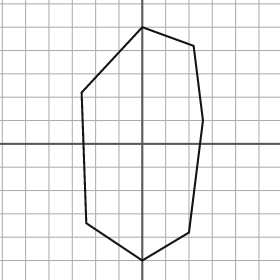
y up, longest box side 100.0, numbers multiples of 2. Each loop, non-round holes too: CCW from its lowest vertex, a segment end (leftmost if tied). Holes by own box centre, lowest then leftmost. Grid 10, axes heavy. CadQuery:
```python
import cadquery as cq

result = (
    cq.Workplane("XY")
    .moveTo(0.0, -50.0)
    .lineTo(20.0, -38.0)
    .lineTo(26.0, 10.0)
    .lineTo(22.0, 42.0)
    .lineTo(0.0, 50.0)
    .lineTo(-26.0, 22.0)
    .lineTo(-24.0, -34.0)
    .close()
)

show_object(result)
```